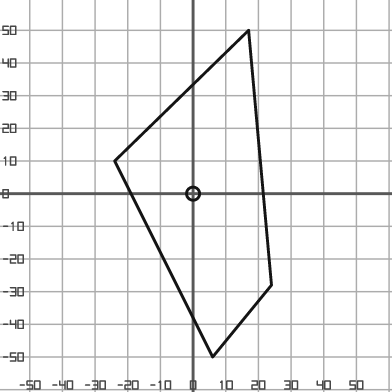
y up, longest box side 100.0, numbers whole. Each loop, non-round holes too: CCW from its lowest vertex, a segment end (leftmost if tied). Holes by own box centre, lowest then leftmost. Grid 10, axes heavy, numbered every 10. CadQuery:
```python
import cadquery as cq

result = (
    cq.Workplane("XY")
    .moveTo(6.0, -50.0)
    .lineTo(24.0, -28.0)
    .lineTo(17.0, 50.0)
    .lineTo(-24.0, 10.0)
    .close()
    .moveTo(0.0, 0.0)
    .circle(2.0)
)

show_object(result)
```